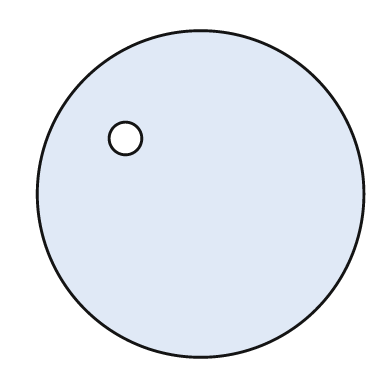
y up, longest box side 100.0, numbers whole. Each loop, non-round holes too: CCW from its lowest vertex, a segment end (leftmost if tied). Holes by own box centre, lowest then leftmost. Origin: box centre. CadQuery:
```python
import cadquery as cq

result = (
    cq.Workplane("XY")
    .moveTo(0.0, 0.0)
    .circle(50.0)
    .moveTo(-23.0, 17.0)
    .circle(5.0)
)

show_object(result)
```